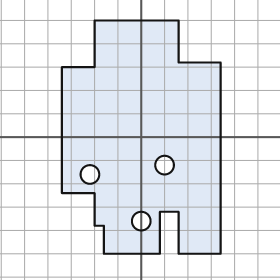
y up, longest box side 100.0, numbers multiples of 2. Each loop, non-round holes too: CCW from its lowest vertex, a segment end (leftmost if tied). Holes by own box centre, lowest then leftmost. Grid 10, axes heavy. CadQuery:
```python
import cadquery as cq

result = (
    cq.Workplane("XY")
    .moveTo(-16.0, -50.0)
    .lineTo(8.0, -50.0)
    .lineTo(8.0, -32.0)
    .lineTo(16.0, -32.0)
    .lineTo(16.0, -50.0)
    .lineTo(34.0, -50.0)
    .lineTo(34.0, 32.0)
    .lineTo(16.0, 32.0)
    .lineTo(16.0, 50.0)
    .lineTo(-20.0, 50.0)
    .lineTo(-20.0, 30.0)
    .lineTo(-34.0, 30.0)
    .lineTo(-34.0, -24.0)
    .lineTo(-20.0, -24.0)
    .lineTo(-20.0, -38.0)
    .lineTo(-16.0, -38.0)
    .close()
    .moveTo(0.0, -36.0)
    .circle(4.0)
    .moveTo(-22.0, -16.0)
    .circle(4.0)
    .moveTo(10.0, -12.0)
    .circle(4.0)
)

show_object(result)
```